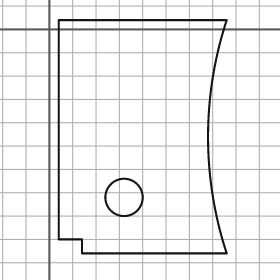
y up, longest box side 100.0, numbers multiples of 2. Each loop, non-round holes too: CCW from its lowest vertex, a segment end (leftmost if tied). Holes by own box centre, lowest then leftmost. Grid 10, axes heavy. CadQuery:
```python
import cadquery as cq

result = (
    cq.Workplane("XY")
    .moveTo(14.0, -96.0)
    .lineTo(76.0, -96.0)
    .threePointArc((68.0, -46.0), (76.0, 4.0))
    .lineTo(4.0, 4.0)
    .lineTo(4.0, -90.0)
    .lineTo(14.0, -90.0)
    .close()
    .moveTo(32.0, -72.0)
    .circle(8.0)
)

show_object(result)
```